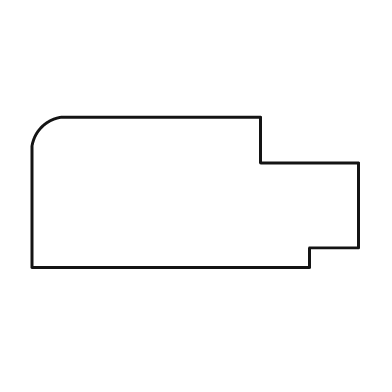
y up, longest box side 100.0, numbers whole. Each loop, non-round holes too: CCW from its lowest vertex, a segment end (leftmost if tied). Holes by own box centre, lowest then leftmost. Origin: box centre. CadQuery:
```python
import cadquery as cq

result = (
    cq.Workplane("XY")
    .moveTo(-50.0, -23.0)
    .lineTo(35.0, -23.0)
    .lineTo(35.0, -17.0)
    .lineTo(50.0, -17.0)
    .lineTo(50.0, 9.0)
    .lineTo(20.0, 9.0)
    .lineTo(20.0, 23.0)
    .lineTo(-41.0, 23.0)
    .threePointArc((-47.0, 20.0), (-50.0, 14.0))
    .close()
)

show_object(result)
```